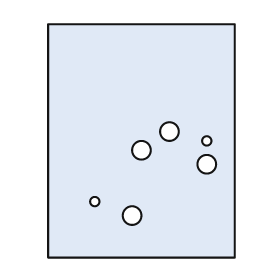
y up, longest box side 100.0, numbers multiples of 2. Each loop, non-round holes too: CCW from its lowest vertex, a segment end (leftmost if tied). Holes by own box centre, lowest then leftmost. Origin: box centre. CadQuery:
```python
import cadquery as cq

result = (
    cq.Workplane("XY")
    .moveTo(-40.0, -50.0)
    .lineTo(40.0, -50.0)
    .lineTo(40.0, 50.0)
    .lineTo(-40.0, 50.0)
    .close()
    .moveTo(-4.0, -32.0)
    .circle(4.0)
    .moveTo(-20.0, -26.0)
    .circle(2.0)
    .moveTo(28.0, -10.0)
    .circle(4.0)
    .moveTo(0.0, -4.0)
    .circle(4.0)
    .moveTo(28.0, 0.0)
    .circle(2.0)
    .moveTo(12.0, 4.0)
    .circle(4.0)
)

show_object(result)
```